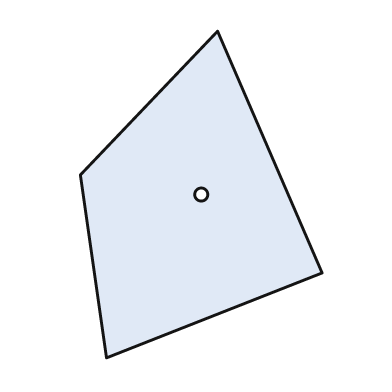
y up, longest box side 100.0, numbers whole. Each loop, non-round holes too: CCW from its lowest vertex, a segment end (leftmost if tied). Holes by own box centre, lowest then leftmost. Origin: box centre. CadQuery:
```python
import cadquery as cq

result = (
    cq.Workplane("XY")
    .moveTo(-29.0, -50.0)
    .lineTo(37.0, -24.0)
    .lineTo(5.0, 50.0)
    .lineTo(-37.0, 6.0)
    .close()
    .moveTo(0.0, 0.0)
    .circle(2.0)
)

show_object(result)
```